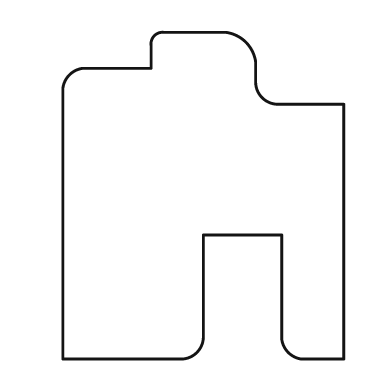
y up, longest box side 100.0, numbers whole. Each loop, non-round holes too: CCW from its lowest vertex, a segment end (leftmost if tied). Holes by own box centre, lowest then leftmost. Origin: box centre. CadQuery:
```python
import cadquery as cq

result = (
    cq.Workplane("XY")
    .moveTo(-43.0, -50.0)
    .lineTo(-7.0, -50.0)
    .threePointArc((-2.0, -48.0), (0.0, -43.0))
    .lineTo(0.0, -12.0)
    .lineTo(24.0, -12.0)
    .lineTo(24.0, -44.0)
    .threePointArc((26.0, -48.0), (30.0, -50.0))
    .lineTo(43.0, -50.0)
    .lineTo(43.0, 28.0)
    .lineTo(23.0, 28.0)
    .threePointArc((18.0, 30.0), (16.0, 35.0))
    .lineTo(16.0, 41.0)
    .threePointArc((13.0, 47.0), (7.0, 50.0))
    .lineTo(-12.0, 50.0)
    .threePointArc((-15.0, 49.0), (-16.0, 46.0))
    .lineTo(-16.0, 39.0)
    .lineTo(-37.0, 39.0)
    .threePointArc((-41.0, 37.0), (-43.0, 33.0))
    .close()
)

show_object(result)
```